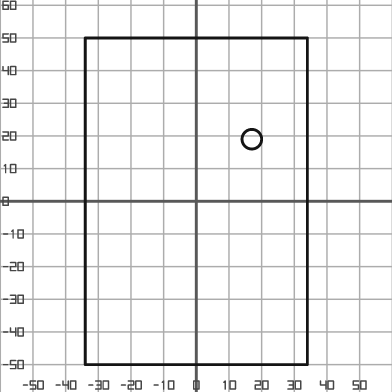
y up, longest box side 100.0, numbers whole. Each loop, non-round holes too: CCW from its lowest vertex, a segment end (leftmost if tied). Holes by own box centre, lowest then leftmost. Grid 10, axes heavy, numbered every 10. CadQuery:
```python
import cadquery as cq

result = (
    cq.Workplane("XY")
    .moveTo(-34.0, -50.0)
    .lineTo(34.0, -50.0)
    .lineTo(34.0, 50.0)
    .lineTo(-34.0, 50.0)
    .close()
    .moveTo(17.0, 19.0)
    .circle(3.0)
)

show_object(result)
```